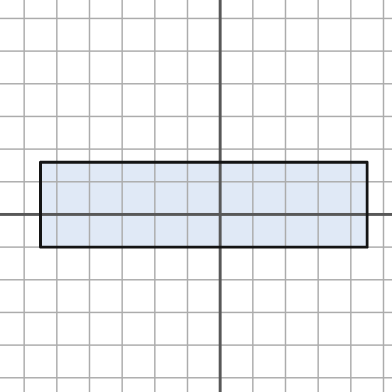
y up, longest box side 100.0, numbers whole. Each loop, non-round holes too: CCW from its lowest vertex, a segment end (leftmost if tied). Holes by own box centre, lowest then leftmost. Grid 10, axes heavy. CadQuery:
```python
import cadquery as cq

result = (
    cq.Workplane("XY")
    .moveTo(-55.0, -10.0)
    .lineTo(45.0, -10.0)
    .lineTo(45.0, 16.0)
    .lineTo(-55.0, 16.0)
    .close()
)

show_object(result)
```